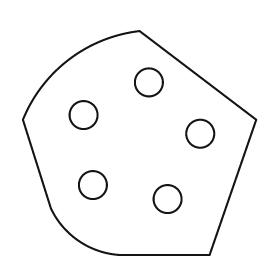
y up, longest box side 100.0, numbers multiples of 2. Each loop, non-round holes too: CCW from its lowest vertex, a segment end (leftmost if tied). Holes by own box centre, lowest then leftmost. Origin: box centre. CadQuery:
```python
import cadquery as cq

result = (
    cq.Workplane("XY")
    .moveTo(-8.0, -48.0)
    .lineTo(30.0, -48.0)
    .lineTo(50.0, 10.0)
    .lineTo(0.0, 48.0)
    .threePointArc((-30.0, 36.0), (-50.0, 10.0))
    .lineTo(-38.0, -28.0)
    .threePointArc((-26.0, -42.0), (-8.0, -48.0))
    .close()
    .moveTo(12.0, -24.0)
    .circle(6.0)
    .moveTo(-20.0, -18.0)
    .circle(6.0)
    .moveTo(26.0, 4.0)
    .circle(6.0)
    .moveTo(-24.0, 12.0)
    .circle(6.0)
    .moveTo(4.0, 26.0)
    .circle(6.0)
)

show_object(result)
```